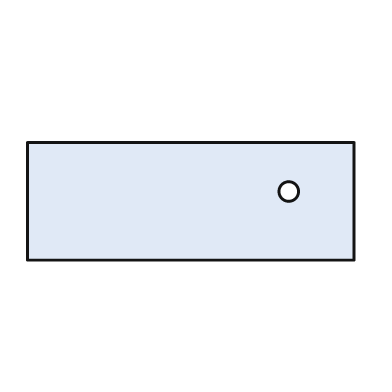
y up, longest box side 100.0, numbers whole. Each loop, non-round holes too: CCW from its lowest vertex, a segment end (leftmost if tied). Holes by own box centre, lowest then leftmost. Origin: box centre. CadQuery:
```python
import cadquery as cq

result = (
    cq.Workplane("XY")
    .moveTo(-50.0, -18.0)
    .lineTo(50.0, -18.0)
    .lineTo(50.0, 18.0)
    .lineTo(-50.0, 18.0)
    .close()
    .moveTo(30.0, 3.0)
    .circle(3.0)
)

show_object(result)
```